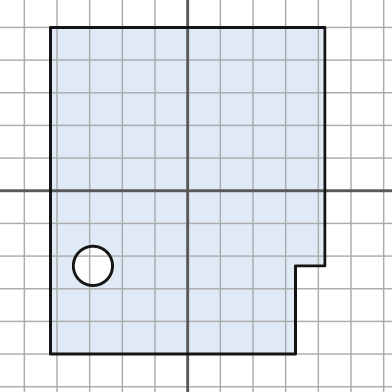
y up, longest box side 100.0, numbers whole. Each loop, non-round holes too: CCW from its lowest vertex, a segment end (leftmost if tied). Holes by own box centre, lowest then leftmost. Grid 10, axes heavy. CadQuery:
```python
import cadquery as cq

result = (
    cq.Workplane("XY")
    .moveTo(-42.0, -50.0)
    .lineTo(33.0, -50.0)
    .lineTo(33.0, -23.0)
    .lineTo(42.0, -23.0)
    .lineTo(42.0, 50.0)
    .lineTo(-42.0, 50.0)
    .close()
    .moveTo(-29.0, -23.0)
    .circle(6.0)
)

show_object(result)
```